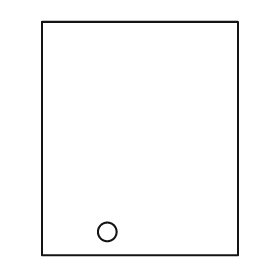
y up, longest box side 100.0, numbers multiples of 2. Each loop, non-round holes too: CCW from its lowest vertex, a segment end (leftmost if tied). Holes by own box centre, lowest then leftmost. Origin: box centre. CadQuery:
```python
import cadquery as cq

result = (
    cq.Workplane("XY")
    .moveTo(-42.0, -50.0)
    .lineTo(42.0, -50.0)
    .lineTo(42.0, 50.0)
    .lineTo(-42.0, 50.0)
    .close()
    .moveTo(-14.0, -40.0)
    .circle(4.0)
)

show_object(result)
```